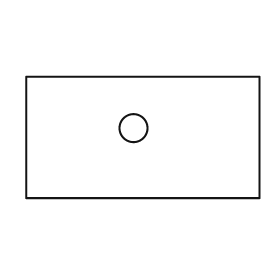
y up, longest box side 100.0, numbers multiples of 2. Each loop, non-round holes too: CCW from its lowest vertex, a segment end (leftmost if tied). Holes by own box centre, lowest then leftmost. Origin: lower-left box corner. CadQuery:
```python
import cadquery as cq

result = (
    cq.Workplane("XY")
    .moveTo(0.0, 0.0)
    .lineTo(100.0, 0.0)
    .lineTo(100.0, 52.0)
    .lineTo(0.0, 52.0)
    .close()
    .moveTo(46.0, 30.0)
    .circle(6.0)
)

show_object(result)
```